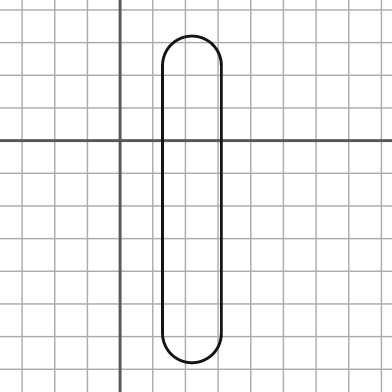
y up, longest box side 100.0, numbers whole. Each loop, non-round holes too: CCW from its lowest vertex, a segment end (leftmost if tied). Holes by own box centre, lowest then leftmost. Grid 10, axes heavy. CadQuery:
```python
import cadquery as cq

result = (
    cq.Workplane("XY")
    .moveTo(13.0, -59.0)
    .threePointArc((22.0, -68.0), (31.0, -59.0))
    .lineTo(31.0, 23.0)
    .threePointArc((22.0, 32.0), (13.0, 23.0))
    .close()
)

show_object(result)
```